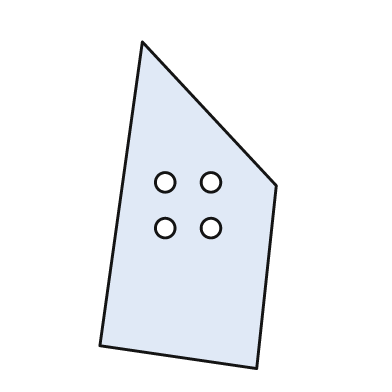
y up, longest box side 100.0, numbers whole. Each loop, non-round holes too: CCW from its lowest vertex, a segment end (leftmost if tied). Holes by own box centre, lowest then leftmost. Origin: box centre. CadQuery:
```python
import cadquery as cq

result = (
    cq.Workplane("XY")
    .moveTo(21.0, -50.0)
    .lineTo(27.0, 6.0)
    .lineTo(-14.0, 50.0)
    .lineTo(-27.0, -43.0)
    .close()
    .moveTo(-7.0, -7.0)
    .circle(3.0)
    .moveTo(7.0, -7.0)
    .circle(3.0)
    .moveTo(-7.0, 7.0)
    .circle(3.0)
    .moveTo(7.0, 7.0)
    .circle(3.0)
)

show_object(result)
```